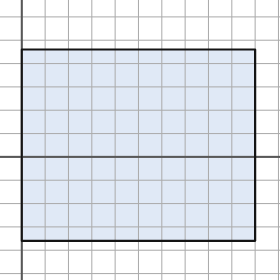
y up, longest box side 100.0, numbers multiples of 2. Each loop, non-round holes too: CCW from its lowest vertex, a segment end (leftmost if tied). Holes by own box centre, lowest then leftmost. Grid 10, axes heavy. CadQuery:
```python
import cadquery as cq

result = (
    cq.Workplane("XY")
    .moveTo(0.0, -36.0)
    .lineTo(100.0, -36.0)
    .lineTo(100.0, 46.0)
    .lineTo(0.0, 46.0)
    .close()
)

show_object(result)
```